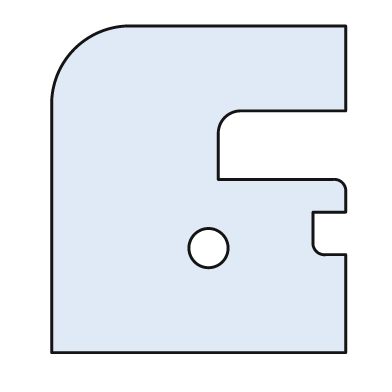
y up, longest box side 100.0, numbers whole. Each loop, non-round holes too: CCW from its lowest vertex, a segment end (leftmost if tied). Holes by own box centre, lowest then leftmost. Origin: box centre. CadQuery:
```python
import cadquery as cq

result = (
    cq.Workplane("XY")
    .moveTo(-45.0, -50.0)
    .lineTo(45.0, -50.0)
    .lineTo(45.0, -20.0)
    .lineTo(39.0, -20.0)
    .threePointArc((36.0, -19.0), (35.0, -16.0))
    .lineTo(35.0, -7.0)
    .lineTo(45.0, -7.0)
    .lineTo(45.0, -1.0)
    .threePointArc((44.0, 2.0), (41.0, 3.0))
    .lineTo(6.0, 3.0)
    .lineTo(6.0, 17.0)
    .threePointArc((8.0, 22.0), (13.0, 24.0))
    .lineTo(45.0, 24.0)
    .lineTo(45.0, 50.0)
    .lineTo(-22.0, 50.0)
    .threePointArc((-38.0, 43.0), (-45.0, 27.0))
    .close()
    .moveTo(3.0, -18.0)
    .circle(6.0)
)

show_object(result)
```